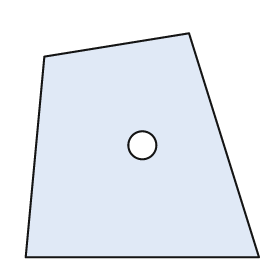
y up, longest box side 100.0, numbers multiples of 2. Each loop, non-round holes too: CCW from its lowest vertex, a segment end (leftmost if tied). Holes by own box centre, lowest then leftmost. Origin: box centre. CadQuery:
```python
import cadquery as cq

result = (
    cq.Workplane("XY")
    .moveTo(-50.0, -48.0)
    .lineTo(50.0, -48.0)
    .lineTo(20.0, 48.0)
    .lineTo(-42.0, 38.0)
    .close()
    .moveTo(0.0, 0.0)
    .circle(6.0)
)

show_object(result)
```